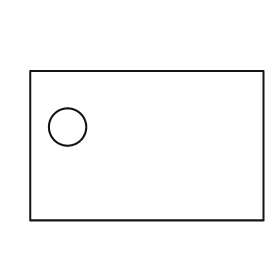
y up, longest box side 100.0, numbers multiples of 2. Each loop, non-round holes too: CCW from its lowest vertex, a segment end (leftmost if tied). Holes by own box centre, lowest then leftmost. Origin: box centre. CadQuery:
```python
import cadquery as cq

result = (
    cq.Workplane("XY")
    .moveTo(-50.0, -32.0)
    .lineTo(50.0, -32.0)
    .lineTo(50.0, 32.0)
    .lineTo(-50.0, 32.0)
    .close()
    .moveTo(-34.0, 8.0)
    .circle(8.0)
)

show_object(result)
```